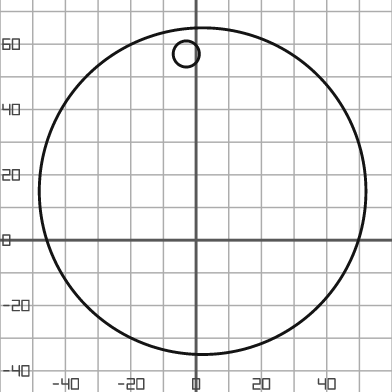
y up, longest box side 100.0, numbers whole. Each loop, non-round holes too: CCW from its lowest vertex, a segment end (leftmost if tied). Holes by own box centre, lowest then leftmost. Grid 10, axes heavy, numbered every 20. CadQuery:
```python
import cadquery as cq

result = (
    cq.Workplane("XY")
    .moveTo(2.0, 15.0)
    .circle(50.0)
    .moveTo(-3.0, 57.0)
    .circle(4.0)
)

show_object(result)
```